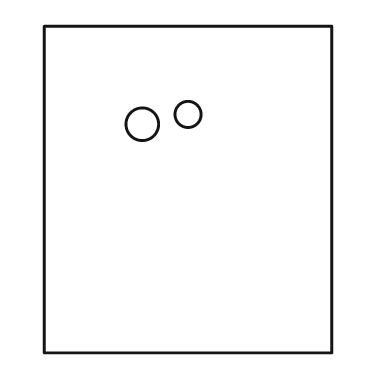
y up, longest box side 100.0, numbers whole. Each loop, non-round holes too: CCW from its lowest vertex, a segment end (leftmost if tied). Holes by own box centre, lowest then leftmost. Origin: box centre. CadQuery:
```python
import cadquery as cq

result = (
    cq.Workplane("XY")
    .moveTo(-44.0, -50.0)
    .lineTo(44.0, -50.0)
    .lineTo(44.0, 50.0)
    .lineTo(-44.0, 50.0)
    .close()
    .moveTo(-14.0, 20.0)
    .circle(5.0)
    .moveTo(0.0, 23.0)
    .circle(4.0)
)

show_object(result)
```